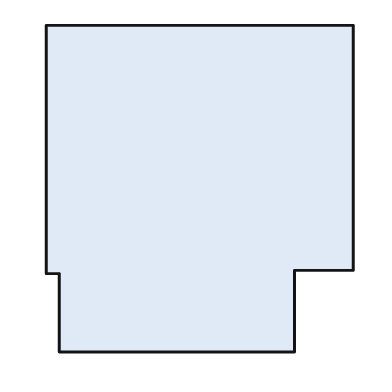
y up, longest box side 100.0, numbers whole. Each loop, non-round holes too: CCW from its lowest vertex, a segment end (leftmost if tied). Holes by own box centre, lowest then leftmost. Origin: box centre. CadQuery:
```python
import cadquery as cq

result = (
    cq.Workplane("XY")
    .moveTo(-43.0, -50.0)
    .lineTo(29.0, -50.0)
    .lineTo(29.0, -25.0)
    .lineTo(47.0, -25.0)
    .lineTo(47.0, 50.0)
    .lineTo(-47.0, 50.0)
    .lineTo(-47.0, -26.0)
    .lineTo(-43.0, -26.0)
    .close()
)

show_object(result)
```